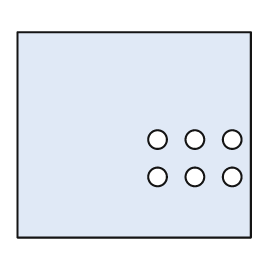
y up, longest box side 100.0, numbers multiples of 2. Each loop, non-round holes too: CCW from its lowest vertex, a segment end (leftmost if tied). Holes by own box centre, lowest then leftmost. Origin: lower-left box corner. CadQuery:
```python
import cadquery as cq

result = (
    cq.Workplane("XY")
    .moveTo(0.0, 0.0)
    .lineTo(100.0, 0.0)
    .lineTo(100.0, 88.0)
    .lineTo(0.0, 88.0)
    .close()
    .moveTo(60.0, 26.0)
    .circle(4.0)
    .moveTo(76.0, 26.0)
    .circle(4.0)
    .moveTo(92.0, 26.0)
    .circle(4.0)
    .moveTo(60.0, 42.0)
    .circle(4.0)
    .moveTo(76.0, 42.0)
    .circle(4.0)
    .moveTo(92.0, 42.0)
    .circle(4.0)
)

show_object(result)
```